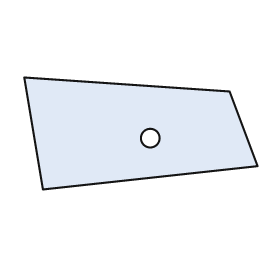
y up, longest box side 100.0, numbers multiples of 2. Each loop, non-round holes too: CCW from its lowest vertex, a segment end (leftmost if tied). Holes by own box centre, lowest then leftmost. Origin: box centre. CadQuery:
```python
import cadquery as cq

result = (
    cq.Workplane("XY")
    .moveTo(-42.0, -24.0)
    .lineTo(50.0, -14.0)
    .lineTo(38.0, 18.0)
    .lineTo(-50.0, 24.0)
    .close()
    .moveTo(4.0, -2.0)
    .circle(4.0)
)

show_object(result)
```